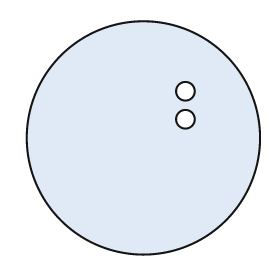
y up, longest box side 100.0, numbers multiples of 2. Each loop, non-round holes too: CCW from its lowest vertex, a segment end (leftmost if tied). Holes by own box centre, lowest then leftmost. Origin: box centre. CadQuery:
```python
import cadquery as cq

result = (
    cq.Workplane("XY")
    .moveTo(0.0, 0.0)
    .circle(50.0)
    .moveTo(18.0, 8.0)
    .circle(4.0)
    .moveTo(18.0, 20.0)
    .circle(4.0)
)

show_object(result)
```